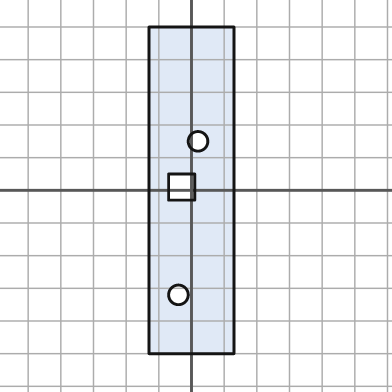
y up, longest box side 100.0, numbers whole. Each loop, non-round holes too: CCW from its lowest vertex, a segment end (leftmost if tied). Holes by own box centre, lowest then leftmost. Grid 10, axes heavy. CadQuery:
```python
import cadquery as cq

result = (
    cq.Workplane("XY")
    .moveTo(-13.0, -50.0)
    .lineTo(13.0, -50.0)
    .lineTo(13.0, 50.0)
    .lineTo(-13.0, 50.0)
    .close()
    .moveTo(-4.0, -32.0)
    .circle(3.0)
    .moveTo(-7.0, -3.0)
    .lineTo(1.0, -3.0)
    .lineTo(1.0, 5.0)
    .lineTo(-7.0, 5.0)
    .close()
    .moveTo(2.0, 15.0)
    .circle(3.0)
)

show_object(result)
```